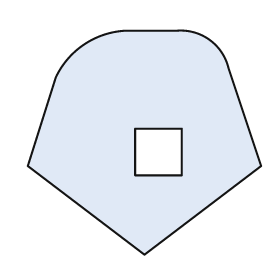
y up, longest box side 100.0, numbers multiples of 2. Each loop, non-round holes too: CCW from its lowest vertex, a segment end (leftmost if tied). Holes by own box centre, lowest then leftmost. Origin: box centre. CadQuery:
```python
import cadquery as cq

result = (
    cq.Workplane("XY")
    .moveTo(0.0, -48.0)
    .lineTo(50.0, -10.0)
    .lineTo(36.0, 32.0)
    .threePointArc((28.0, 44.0), (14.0, 48.0))
    .lineTo(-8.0, 48.0)
    .threePointArc((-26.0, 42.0), (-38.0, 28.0))
    .lineTo(-50.0, -10.0)
    .close()
    .moveTo(-4.0, -14.0)
    .lineTo(16.0, -14.0)
    .lineTo(16.0, 6.0)
    .lineTo(-4.0, 6.0)
    .close()
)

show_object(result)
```